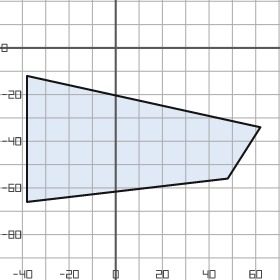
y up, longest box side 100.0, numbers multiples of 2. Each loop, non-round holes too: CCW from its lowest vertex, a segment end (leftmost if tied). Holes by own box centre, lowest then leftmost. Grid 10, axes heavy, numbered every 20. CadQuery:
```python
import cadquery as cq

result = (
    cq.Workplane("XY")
    .moveTo(-38.0, -66.0)
    .lineTo(48.0, -56.0)
    .lineTo(62.0, -34.0)
    .lineTo(-38.0, -12.0)
    .close()
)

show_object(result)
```